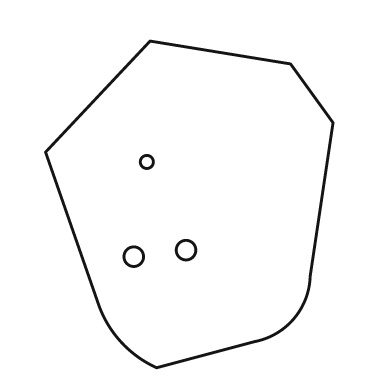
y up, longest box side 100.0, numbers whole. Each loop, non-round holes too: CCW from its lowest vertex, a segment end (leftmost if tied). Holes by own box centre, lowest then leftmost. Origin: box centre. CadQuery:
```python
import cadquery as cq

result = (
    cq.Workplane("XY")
    .moveTo(-10.0, -50.0)
    .lineTo(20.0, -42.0)
    .threePointArc((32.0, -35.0), (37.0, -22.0))
    .lineTo(44.0, 25.0)
    .lineTo(31.0, 43.0)
    .lineTo(-12.0, 50.0)
    .lineTo(-44.0, 16.0)
    .lineTo(-28.0, -30.0)
    .threePointArc((-21.0, -42.0), (-10.0, -50.0))
    .close()
    .moveTo(-17.0, -16.0)
    .circle(3.0)
    .moveTo(-1.0, -14.0)
    .circle(3.0)
    .moveTo(-13.0, 13.0)
    .circle(2.0)
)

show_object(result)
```